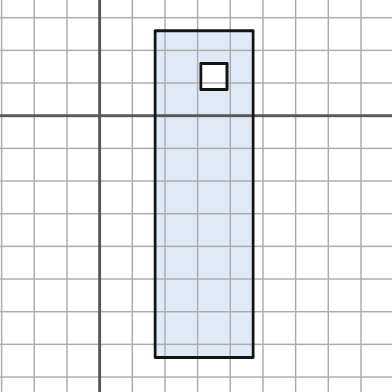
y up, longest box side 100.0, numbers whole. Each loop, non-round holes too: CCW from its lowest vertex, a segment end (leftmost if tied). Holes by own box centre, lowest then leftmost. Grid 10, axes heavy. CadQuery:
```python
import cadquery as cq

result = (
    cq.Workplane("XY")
    .moveTo(17.0, -74.0)
    .lineTo(47.0, -74.0)
    .lineTo(47.0, 26.0)
    .lineTo(17.0, 26.0)
    .close()
    .moveTo(31.0, 8.0)
    .lineTo(39.0, 8.0)
    .lineTo(39.0, 16.0)
    .lineTo(31.0, 16.0)
    .close()
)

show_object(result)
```